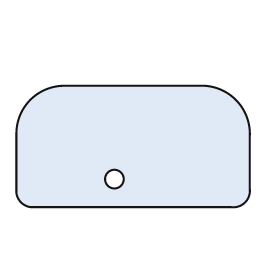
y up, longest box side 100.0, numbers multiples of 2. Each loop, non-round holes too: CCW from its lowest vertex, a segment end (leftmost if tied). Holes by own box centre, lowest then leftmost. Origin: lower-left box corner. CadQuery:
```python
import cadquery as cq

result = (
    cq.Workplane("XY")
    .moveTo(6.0, 0.0)
    .lineTo(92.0, 0.0)
    .threePointArc((98.0, 2.0), (100.0, 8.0))
    .lineTo(100.0, 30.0)
    .threePointArc((94.0, 46.0), (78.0, 52.0))
    .lineTo(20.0, 52.0)
    .threePointArc((6.0, 46.0), (0.0, 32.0))
    .lineTo(0.0, 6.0)
    .threePointArc((2.0, 2.0), (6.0, 0.0))
    .close()
    .moveTo(42.0, 12.0)
    .circle(4.0)
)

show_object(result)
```